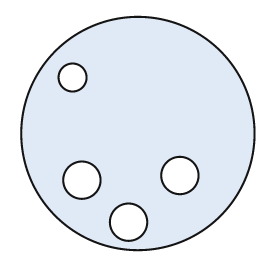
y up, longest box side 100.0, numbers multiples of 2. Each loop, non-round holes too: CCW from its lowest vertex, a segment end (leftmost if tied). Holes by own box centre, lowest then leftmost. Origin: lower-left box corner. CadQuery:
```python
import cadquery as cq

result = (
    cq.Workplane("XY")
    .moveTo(50.0, 50.0)
    .circle(50.0)
    .moveTo(46.0, 12.0)
    .circle(8.0)
    .moveTo(26.0, 30.0)
    .circle(8.0)
    .moveTo(68.0, 32.0)
    .circle(8.0)
    .moveTo(22.0, 74.0)
    .circle(6.0)
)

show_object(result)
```